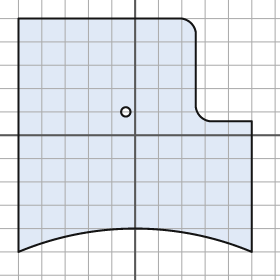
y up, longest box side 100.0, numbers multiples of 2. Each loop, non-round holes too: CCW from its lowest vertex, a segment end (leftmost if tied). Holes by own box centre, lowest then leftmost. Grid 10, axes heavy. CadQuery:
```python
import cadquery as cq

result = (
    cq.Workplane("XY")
    .moveTo(-50.0, -50.0)
    .threePointArc((0.0, -40.0), (50.0, -50.0))
    .lineTo(50.0, 6.0)
    .lineTo(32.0, 6.0)
    .threePointArc((28.0, 8.0), (26.0, 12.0))
    .lineTo(26.0, 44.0)
    .threePointArc((24.0, 48.0), (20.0, 50.0))
    .lineTo(-50.0, 50.0)
    .close()
    .moveTo(-4.0, 10.0)
    .circle(2.0)
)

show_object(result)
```